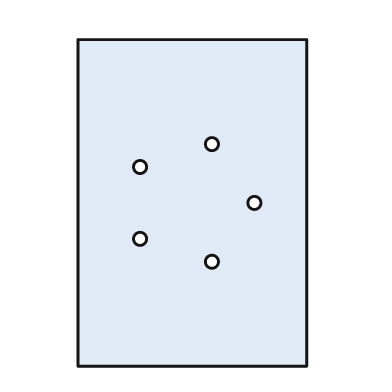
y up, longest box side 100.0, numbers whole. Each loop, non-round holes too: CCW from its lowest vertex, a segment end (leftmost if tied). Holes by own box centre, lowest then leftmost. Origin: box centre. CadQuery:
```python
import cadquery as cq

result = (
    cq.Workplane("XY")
    .moveTo(-35.0, -50.0)
    .lineTo(35.0, -50.0)
    .lineTo(35.0, 50.0)
    .lineTo(-35.0, 50.0)
    .close()
    .moveTo(6.0, -18.0)
    .circle(2.0)
    .moveTo(-16.0, -11.0)
    .circle(2.0)
    .moveTo(19.0, 0.0)
    .circle(2.0)
    .moveTo(-16.0, 11.0)
    .circle(2.0)
    .moveTo(6.0, 18.0)
    .circle(2.0)
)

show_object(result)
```